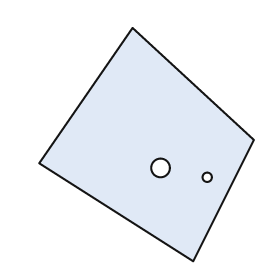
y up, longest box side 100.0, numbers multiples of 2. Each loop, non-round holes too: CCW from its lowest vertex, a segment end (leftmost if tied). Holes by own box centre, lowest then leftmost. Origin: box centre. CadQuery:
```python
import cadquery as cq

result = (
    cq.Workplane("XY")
    .moveTo(20.0, -50.0)
    .lineTo(46.0, 2.0)
    .lineTo(-6.0, 50.0)
    .lineTo(-46.0, -8.0)
    .close()
    .moveTo(26.0, -14.0)
    .circle(2.0)
    .moveTo(6.0, -10.0)
    .circle(4.0)
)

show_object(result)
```